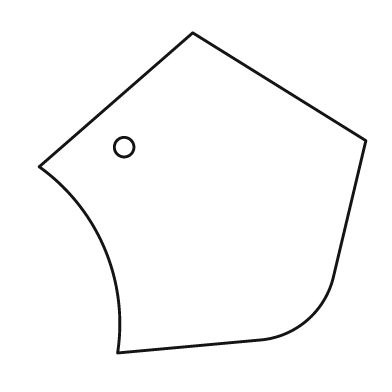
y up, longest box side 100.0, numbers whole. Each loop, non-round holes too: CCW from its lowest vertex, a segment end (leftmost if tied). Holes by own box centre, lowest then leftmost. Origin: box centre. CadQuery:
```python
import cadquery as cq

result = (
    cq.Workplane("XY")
    .moveTo(-26.0, -49.0)
    .lineTo(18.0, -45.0)
    .threePointArc((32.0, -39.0), (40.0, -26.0))
    .lineTo(50.0, 16.0)
    .lineTo(-3.0, 49.0)
    .lineTo(-50.0, 8.0)
    .threePointArc((-30.0, -17.0), (-26.0, -49.0))
    .close()
    .moveTo(-24.0, 14.0)
    .circle(3.0)
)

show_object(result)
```